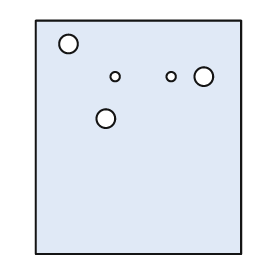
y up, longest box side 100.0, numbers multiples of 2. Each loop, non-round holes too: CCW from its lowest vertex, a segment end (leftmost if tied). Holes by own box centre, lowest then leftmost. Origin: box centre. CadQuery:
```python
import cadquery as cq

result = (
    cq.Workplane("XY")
    .moveTo(-44.0, -50.0)
    .lineTo(44.0, -50.0)
    .lineTo(44.0, 50.0)
    .lineTo(-44.0, 50.0)
    .close()
    .moveTo(-14.0, 8.0)
    .circle(4.0)
    .moveTo(-10.0, 26.0)
    .circle(2.0)
    .moveTo(14.0, 26.0)
    .circle(2.0)
    .moveTo(28.0, 26.0)
    .circle(4.0)
    .moveTo(-30.0, 40.0)
    .circle(4.0)
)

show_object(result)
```